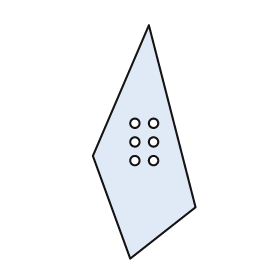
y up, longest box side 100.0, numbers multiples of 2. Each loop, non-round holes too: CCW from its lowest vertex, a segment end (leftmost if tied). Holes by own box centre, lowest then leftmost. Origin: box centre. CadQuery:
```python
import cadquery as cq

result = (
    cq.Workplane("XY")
    .moveTo(-6.0, -50.0)
    .lineTo(22.0, -28.0)
    .lineTo(2.0, 50.0)
    .lineTo(-22.0, -6.0)
    .close()
    .moveTo(-4.0, -8.0)
    .circle(2.0)
    .moveTo(4.0, -8.0)
    .circle(2.0)
    .moveTo(-4.0, 0.0)
    .circle(2.0)
    .moveTo(4.0, 0.0)
    .circle(2.0)
    .moveTo(-4.0, 8.0)
    .circle(2.0)
    .moveTo(4.0, 8.0)
    .circle(2.0)
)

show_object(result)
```